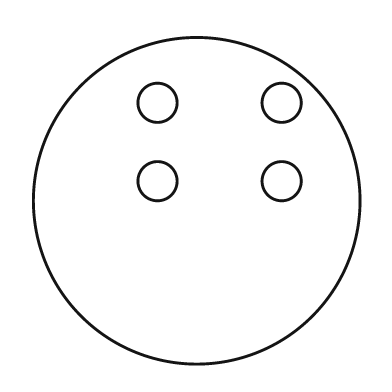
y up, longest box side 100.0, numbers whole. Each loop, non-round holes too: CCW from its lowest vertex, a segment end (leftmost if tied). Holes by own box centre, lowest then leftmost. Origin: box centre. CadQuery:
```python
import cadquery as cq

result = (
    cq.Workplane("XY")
    .moveTo(0.0, 0.0)
    .circle(50.0)
    .moveTo(-12.0, 6.0)
    .circle(6.0)
    .moveTo(26.0, 6.0)
    .circle(6.0)
    .moveTo(-12.0, 30.0)
    .circle(6.0)
    .moveTo(26.0, 30.0)
    .circle(6.0)
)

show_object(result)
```